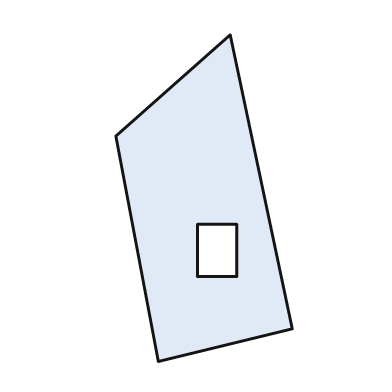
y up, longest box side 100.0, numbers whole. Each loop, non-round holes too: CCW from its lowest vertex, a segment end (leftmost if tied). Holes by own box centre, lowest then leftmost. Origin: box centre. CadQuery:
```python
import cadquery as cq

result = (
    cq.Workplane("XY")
    .moveTo(-14.0, -50.0)
    .lineTo(27.0, -40.0)
    .lineTo(8.0, 50.0)
    .lineTo(-27.0, 19.0)
    .close()
    .moveTo(-2.0, -24.0)
    .lineTo(10.0, -24.0)
    .lineTo(10.0, -8.0)
    .lineTo(-2.0, -8.0)
    .close()
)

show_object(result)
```